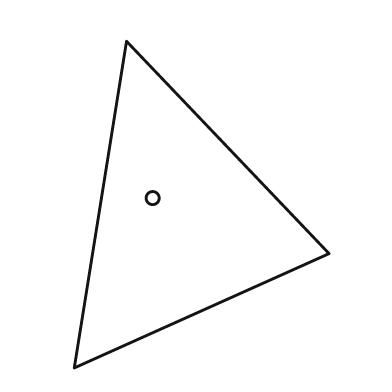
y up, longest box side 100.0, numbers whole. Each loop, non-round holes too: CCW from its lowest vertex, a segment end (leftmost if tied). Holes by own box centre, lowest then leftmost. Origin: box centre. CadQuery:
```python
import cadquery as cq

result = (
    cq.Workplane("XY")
    .moveTo(-39.0, -50.0)
    .lineTo(39.0, -15.0)
    .lineTo(-23.0, 50.0)
    .close()
    .moveTo(-15.0, 2.0)
    .circle(2.0)
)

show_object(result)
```